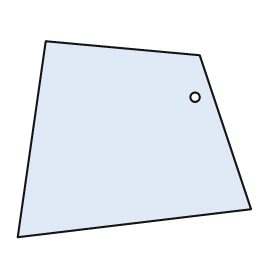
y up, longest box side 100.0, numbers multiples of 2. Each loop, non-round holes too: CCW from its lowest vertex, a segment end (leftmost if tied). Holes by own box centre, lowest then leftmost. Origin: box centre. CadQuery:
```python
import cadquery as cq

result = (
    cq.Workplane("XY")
    .moveTo(-50.0, -42.0)
    .lineTo(50.0, -30.0)
    .lineTo(28.0, 36.0)
    .lineTo(-38.0, 42.0)
    .close()
    .moveTo(26.0, 18.0)
    .circle(2.0)
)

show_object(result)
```